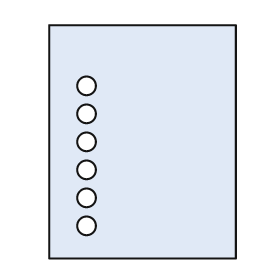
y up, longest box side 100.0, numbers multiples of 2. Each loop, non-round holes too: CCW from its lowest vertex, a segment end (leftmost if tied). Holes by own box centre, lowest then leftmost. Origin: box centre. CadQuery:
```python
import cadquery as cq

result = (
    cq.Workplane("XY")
    .moveTo(-40.0, -50.0)
    .lineTo(40.0, -50.0)
    .lineTo(40.0, 50.0)
    .lineTo(-40.0, 50.0)
    .close()
    .moveTo(-24.0, -36.0)
    .circle(4.0)
    .moveTo(-24.0, -24.0)
    .circle(4.0)
    .moveTo(-24.0, -12.0)
    .circle(4.0)
    .moveTo(-24.0, 0.0)
    .circle(4.0)
    .moveTo(-24.0, 12.0)
    .circle(4.0)
    .moveTo(-24.0, 24.0)
    .circle(4.0)
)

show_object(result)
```